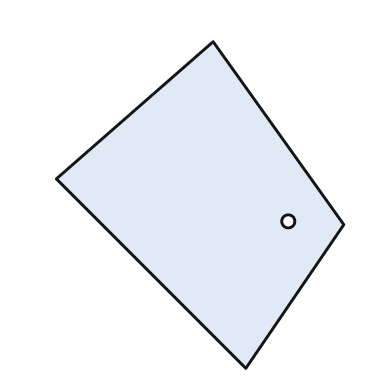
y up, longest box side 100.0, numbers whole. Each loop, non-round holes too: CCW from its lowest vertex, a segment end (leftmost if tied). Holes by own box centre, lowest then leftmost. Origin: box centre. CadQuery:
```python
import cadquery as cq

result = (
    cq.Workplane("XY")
    .moveTo(14.0, -50.0)
    .lineTo(44.0, -6.0)
    .lineTo(4.0, 50.0)
    .lineTo(-44.0, 8.0)
    .close()
    .moveTo(27.0, -5.0)
    .circle(2.0)
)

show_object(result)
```